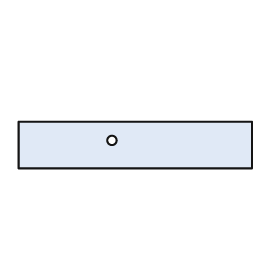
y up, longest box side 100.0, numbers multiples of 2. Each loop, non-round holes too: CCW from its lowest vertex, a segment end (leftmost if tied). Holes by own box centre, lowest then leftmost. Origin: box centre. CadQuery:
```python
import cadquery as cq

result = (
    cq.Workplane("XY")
    .moveTo(-50.0, -10.0)
    .lineTo(50.0, -10.0)
    .lineTo(50.0, 10.0)
    .lineTo(-50.0, 10.0)
    .close()
    .moveTo(-10.0, 2.0)
    .circle(2.0)
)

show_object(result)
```